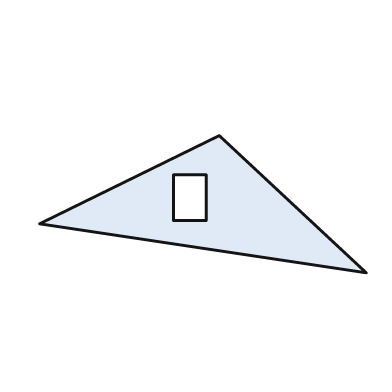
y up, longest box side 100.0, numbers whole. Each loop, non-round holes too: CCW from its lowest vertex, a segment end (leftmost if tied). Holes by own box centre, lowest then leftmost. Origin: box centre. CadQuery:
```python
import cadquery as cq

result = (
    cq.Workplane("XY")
    .moveTo(50.0, -21.0)
    .lineTo(5.0, 21.0)
    .lineTo(-50.0, -6.0)
    .close()
    .moveTo(-9.0, -5.0)
    .lineTo(1.0, -5.0)
    .lineTo(1.0, 9.0)
    .lineTo(-9.0, 9.0)
    .close()
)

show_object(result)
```